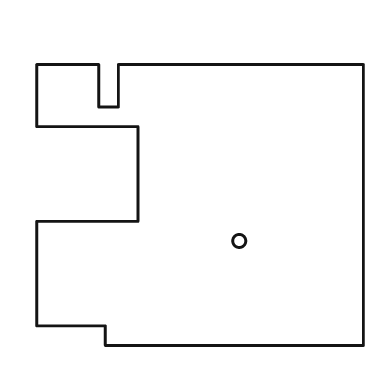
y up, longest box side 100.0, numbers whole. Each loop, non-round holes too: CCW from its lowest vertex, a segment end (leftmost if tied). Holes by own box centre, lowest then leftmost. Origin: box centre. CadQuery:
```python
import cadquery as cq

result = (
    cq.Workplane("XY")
    .moveTo(-29.0, -43.0)
    .lineTo(50.0, -43.0)
    .lineTo(50.0, 43.0)
    .lineTo(-25.0, 43.0)
    .lineTo(-25.0, 30.0)
    .lineTo(-31.0, 30.0)
    .lineTo(-31.0, 43.0)
    .lineTo(-50.0, 43.0)
    .lineTo(-50.0, 24.0)
    .lineTo(-19.0, 24.0)
    .lineTo(-19.0, -5.0)
    .lineTo(-50.0, -5.0)
    .lineTo(-50.0, -37.0)
    .lineTo(-29.0, -37.0)
    .close()
    .moveTo(12.0, -11.0)
    .circle(2.0)
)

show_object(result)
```